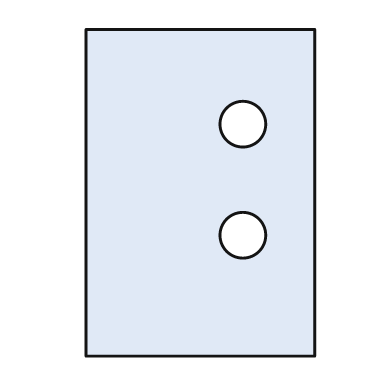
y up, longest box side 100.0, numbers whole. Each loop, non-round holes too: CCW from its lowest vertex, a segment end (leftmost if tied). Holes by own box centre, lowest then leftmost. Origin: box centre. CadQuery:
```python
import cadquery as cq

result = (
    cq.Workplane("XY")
    .moveTo(-35.0, -50.0)
    .lineTo(35.0, -50.0)
    .lineTo(35.0, 50.0)
    .lineTo(-35.0, 50.0)
    .close()
    .moveTo(13.0, -13.0)
    .circle(7.0)
    .moveTo(13.0, 21.0)
    .circle(7.0)
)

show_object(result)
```